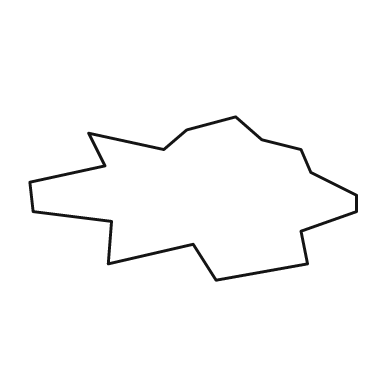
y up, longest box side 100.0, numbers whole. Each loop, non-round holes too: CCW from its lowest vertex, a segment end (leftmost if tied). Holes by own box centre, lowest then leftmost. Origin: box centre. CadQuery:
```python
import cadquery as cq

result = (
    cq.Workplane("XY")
    .moveTo(7.0, -25.0)
    .lineTo(35.0, -20.0)
    .lineTo(33.0, -10.0)
    .lineTo(50.0, -4.0)
    .lineTo(50.0, 1.0)
    .lineTo(36.0, 8.0)
    .lineTo(33.0, 15.0)
    .lineTo(21.0, 18.0)
    .lineTo(13.0, 25.0)
    .lineTo(-2.0, 21.0)
    .lineTo(-9.0, 15.0)
    .lineTo(-32.0, 20.0)
    .lineTo(-27.0, 10.0)
    .lineTo(-50.0, 5.0)
    .lineTo(-49.0, -4.0)
    .lineTo(-25.0, -7.0)
    .lineTo(-26.0, -20.0)
    .lineTo(0.0, -14.0)
    .close()
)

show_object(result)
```